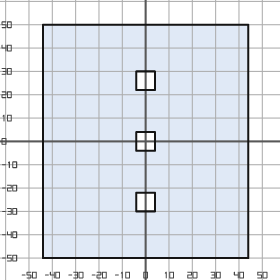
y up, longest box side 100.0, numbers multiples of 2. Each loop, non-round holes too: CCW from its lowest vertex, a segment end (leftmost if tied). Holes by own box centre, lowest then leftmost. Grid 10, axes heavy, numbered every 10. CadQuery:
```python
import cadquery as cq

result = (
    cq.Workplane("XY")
    .moveTo(-44.0, -50.0)
    .lineTo(44.0, -50.0)
    .lineTo(44.0, 50.0)
    .lineTo(-44.0, 50.0)
    .close()
    .moveTo(-4.0, -30.0)
    .lineTo(4.0, -30.0)
    .lineTo(4.0, -22.0)
    .lineTo(-4.0, -22.0)
    .close()
    .moveTo(-4.0, -4.0)
    .lineTo(4.0, -4.0)
    .lineTo(4.0, 4.0)
    .lineTo(-4.0, 4.0)
    .close()
    .moveTo(-4.0, 22.0)
    .lineTo(4.0, 22.0)
    .lineTo(4.0, 30.0)
    .lineTo(-4.0, 30.0)
    .close()
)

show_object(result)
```